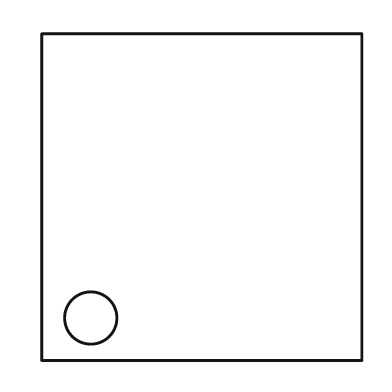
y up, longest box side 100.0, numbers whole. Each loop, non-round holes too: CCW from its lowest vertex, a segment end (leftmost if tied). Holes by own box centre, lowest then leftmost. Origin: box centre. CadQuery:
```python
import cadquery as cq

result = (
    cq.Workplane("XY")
    .moveTo(-49.0, -50.0)
    .lineTo(49.0, -50.0)
    .lineTo(49.0, 50.0)
    .lineTo(-49.0, 50.0)
    .close()
    .moveTo(-34.0, -37.0)
    .circle(8.0)
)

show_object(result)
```